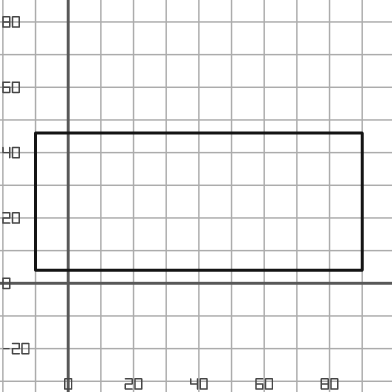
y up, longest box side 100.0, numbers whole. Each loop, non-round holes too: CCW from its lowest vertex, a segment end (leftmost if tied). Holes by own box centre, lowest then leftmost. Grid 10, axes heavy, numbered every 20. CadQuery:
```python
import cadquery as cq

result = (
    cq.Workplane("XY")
    .moveTo(-10.0, 4.0)
    .lineTo(90.0, 4.0)
    .lineTo(90.0, 46.0)
    .lineTo(-10.0, 46.0)
    .close()
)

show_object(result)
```